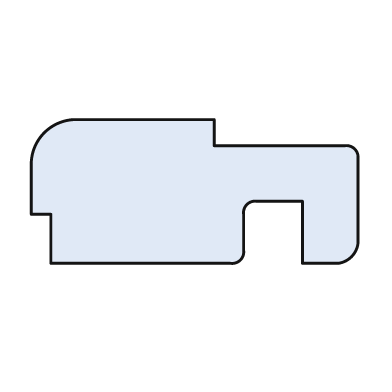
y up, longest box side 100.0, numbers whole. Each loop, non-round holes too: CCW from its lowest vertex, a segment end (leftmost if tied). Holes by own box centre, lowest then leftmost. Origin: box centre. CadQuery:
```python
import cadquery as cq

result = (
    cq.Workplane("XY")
    .moveTo(-44.0, -22.0)
    .lineTo(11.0, -22.0)
    .threePointArc((14.0, -21.0), (15.0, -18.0))
    .lineTo(15.0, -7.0)
    .threePointArc((16.0, -4.0), (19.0, -3.0))
    .lineTo(33.0, -3.0)
    .lineTo(33.0, -22.0)
    .lineTo(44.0, -22.0)
    .threePointArc((48.0, -20.0), (50.0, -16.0))
    .lineTo(50.0, 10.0)
    .threePointArc((49.0, 13.0), (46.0, 14.0))
    .lineTo(6.0, 14.0)
    .lineTo(6.0, 22.0)
    .lineTo(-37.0, 22.0)
    .threePointArc((-46.0, 18.0), (-50.0, 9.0))
    .lineTo(-50.0, -7.0)
    .lineTo(-44.0, -7.0)
    .close()
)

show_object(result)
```